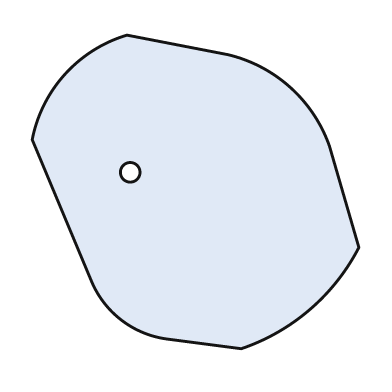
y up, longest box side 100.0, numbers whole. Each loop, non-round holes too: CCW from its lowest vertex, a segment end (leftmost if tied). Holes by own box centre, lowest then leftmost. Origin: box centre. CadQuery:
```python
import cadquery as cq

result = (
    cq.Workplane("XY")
    .moveTo(14.0, -48.0)
    .threePointArc((35.0, -36.0), (50.0, -17.0))
    .lineTo(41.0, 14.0)
    .threePointArc((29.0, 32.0), (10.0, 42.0))
    .lineTo(-21.0, 48.0)
    .threePointArc((-40.0, 36.0), (-50.0, 16.0))
    .lineTo(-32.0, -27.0)
    .threePointArc((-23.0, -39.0), (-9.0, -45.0))
    .close()
    .moveTo(-20.0, 6.0)
    .circle(3.0)
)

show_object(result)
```